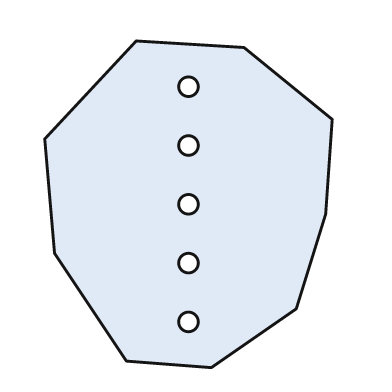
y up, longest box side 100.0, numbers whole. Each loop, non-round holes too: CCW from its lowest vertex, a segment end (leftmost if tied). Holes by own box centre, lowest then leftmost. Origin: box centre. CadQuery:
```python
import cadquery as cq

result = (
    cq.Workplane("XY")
    .moveTo(7.0, -50.0)
    .lineTo(33.0, -32.0)
    .lineTo(42.0, -3.0)
    .lineTo(44.0, 26.0)
    .lineTo(17.0, 48.0)
    .lineTo(-16.0, 50.0)
    .lineTo(-44.0, 20.0)
    .lineTo(-41.0, -15.0)
    .lineTo(-19.0, -48.0)
    .close()
    .moveTo(0.0, -36.0)
    .circle(3.0)
    .moveTo(0.0, -18.0)
    .circle(3.0)
    .moveTo(0.0, 0.0)
    .circle(3.0)
    .moveTo(0.0, 18.0)
    .circle(3.0)
    .moveTo(0.0, 36.0)
    .circle(3.0)
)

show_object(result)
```